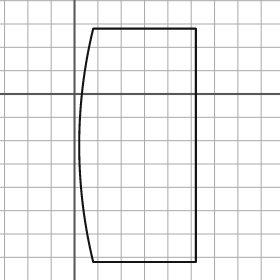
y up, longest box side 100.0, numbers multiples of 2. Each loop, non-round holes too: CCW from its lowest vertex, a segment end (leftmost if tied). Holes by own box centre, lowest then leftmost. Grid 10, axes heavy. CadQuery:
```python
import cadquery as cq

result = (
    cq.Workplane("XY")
    .moveTo(8.0, -72.0)
    .lineTo(52.0, -72.0)
    .lineTo(52.0, 28.0)
    .lineTo(8.0, 28.0)
    .threePointArc((2.0, -22.0), (8.0, -72.0))
    .close()
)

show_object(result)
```